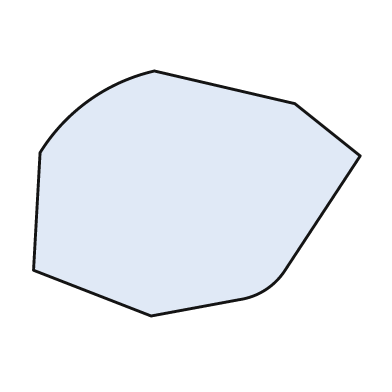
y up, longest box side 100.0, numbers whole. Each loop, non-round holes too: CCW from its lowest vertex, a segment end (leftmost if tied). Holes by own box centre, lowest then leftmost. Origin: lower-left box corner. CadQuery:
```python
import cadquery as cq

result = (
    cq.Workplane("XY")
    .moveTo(36.0, 0.0)
    .lineTo(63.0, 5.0)
    .threePointArc((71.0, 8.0), (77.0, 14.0))
    .lineTo(100.0, 49.0)
    .lineTo(80.0, 65.0)
    .lineTo(37.0, 75.0)
    .threePointArc((17.0, 66.0), (2.0, 50.0))
    .lineTo(0.0, 14.0)
    .close()
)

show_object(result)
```